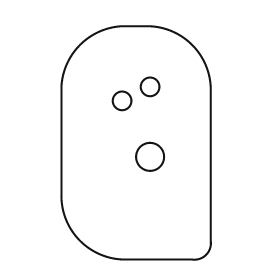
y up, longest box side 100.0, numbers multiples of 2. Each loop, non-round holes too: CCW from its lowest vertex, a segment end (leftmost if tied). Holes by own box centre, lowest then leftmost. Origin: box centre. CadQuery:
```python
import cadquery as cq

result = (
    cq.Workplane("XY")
    .moveTo(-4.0, -50.0)
    .lineTo(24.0, -50.0)
    .threePointArc((30.0, -48.0), (32.0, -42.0))
    .lineTo(32.0, 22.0)
    .threePointArc((24.0, 42.0), (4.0, 50.0))
    .lineTo(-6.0, 50.0)
    .threePointArc((-24.0, 42.0), (-32.0, 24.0))
    .lineTo(-32.0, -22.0)
    .threePointArc((-24.0, -42.0), (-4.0, -50.0))
    .close()
    .moveTo(6.0, -6.0)
    .circle(6.0)
    .moveTo(-6.0, 18.0)
    .circle(4.0)
    .moveTo(6.0, 24.0)
    .circle(4.0)
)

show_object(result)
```